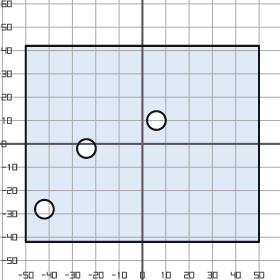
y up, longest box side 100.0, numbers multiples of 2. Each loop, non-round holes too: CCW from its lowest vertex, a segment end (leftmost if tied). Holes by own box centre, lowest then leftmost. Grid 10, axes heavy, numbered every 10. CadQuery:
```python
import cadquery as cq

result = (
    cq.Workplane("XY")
    .moveTo(-50.0, -42.0)
    .lineTo(50.0, -42.0)
    .lineTo(50.0, 42.0)
    .lineTo(-50.0, 42.0)
    .close()
    .moveTo(-42.0, -28.0)
    .circle(4.0)
    .moveTo(-24.0, -2.0)
    .circle(4.0)
    .moveTo(6.0, 10.0)
    .circle(4.0)
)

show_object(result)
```